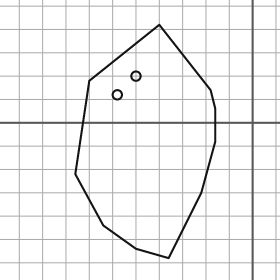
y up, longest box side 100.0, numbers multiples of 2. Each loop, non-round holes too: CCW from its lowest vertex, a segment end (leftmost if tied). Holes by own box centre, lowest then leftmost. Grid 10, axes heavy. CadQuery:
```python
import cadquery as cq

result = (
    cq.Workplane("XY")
    .moveTo(-36.0, -58.0)
    .lineTo(-22.0, -30.0)
    .lineTo(-16.0, -8.0)
    .lineTo(-16.0, 6.0)
    .lineTo(-18.0, 14.0)
    .lineTo(-40.0, 42.0)
    .lineTo(-70.0, 18.0)
    .lineTo(-76.0, -22.0)
    .lineTo(-64.0, -44.0)
    .lineTo(-50.0, -54.0)
    .close()
    .moveTo(-58.0, 12.0)
    .circle(2.0)
    .moveTo(-50.0, 20.0)
    .circle(2.0)
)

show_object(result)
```